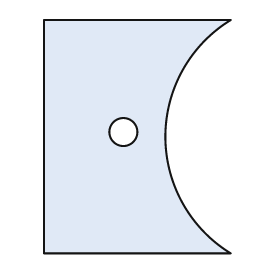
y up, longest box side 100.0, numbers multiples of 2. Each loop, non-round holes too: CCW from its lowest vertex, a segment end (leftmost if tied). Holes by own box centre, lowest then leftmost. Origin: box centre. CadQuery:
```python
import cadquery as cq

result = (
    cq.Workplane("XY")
    .moveTo(-40.0, -50.0)
    .lineTo(40.0, -50.0)
    .threePointArc((12.0, 0.0), (40.0, 50.0))
    .lineTo(-40.0, 50.0)
    .close()
    .moveTo(-6.0, 2.0)
    .circle(6.0)
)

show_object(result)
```